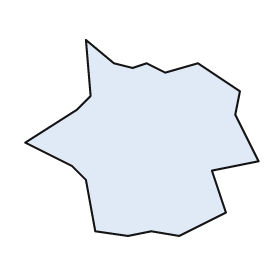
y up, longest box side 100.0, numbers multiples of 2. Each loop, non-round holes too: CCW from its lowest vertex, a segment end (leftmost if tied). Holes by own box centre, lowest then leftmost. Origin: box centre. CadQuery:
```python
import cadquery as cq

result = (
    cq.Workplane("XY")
    .moveTo(-6.0, -42.0)
    .lineTo(4.0, -40.0)
    .lineTo(16.0, -42.0)
    .lineTo(36.0, -32.0)
    .lineTo(30.0, -14.0)
    .lineTo(50.0, -10.0)
    .lineTo(40.0, 10.0)
    .lineTo(42.0, 20.0)
    .lineTo(24.0, 32.0)
    .lineTo(10.0, 28.0)
    .lineTo(2.0, 32.0)
    .lineTo(-4.0, 30.0)
    .lineTo(-12.0, 32.0)
    .lineTo(-24.0, 42.0)
    .lineTo(-22.0, 18.0)
    .lineTo(-28.0, 12.0)
    .lineTo(-50.0, -2.0)
    .lineTo(-30.0, -12.0)
    .lineTo(-24.0, -18.0)
    .lineTo(-20.0, -40.0)
    .close()
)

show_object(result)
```